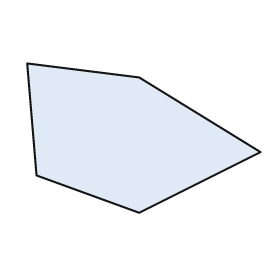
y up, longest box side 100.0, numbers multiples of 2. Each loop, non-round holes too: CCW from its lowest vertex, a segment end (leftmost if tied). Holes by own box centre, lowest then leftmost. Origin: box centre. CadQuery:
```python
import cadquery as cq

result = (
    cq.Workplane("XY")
    .moveTo(-2.0, -32.0)
    .lineTo(50.0, -6.0)
    .lineTo(-2.0, 26.0)
    .lineTo(-50.0, 32.0)
    .lineTo(-46.0, -16.0)
    .close()
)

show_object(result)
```